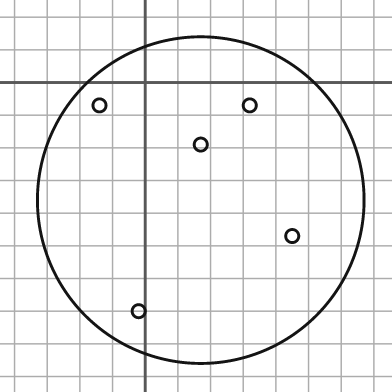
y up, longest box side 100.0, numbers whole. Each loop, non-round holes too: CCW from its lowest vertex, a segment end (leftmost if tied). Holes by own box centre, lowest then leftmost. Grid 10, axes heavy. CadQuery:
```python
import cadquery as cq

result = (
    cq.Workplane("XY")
    .moveTo(17.0, -36.0)
    .circle(50.0)
    .moveTo(-2.0, -70.0)
    .circle(2.0)
    .moveTo(45.0, -47.0)
    .circle(2.0)
    .moveTo(17.0, -19.0)
    .circle(2.0)
    .moveTo(-14.0, -7.0)
    .circle(2.0)
    .moveTo(32.0, -7.0)
    .circle(2.0)
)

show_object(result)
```